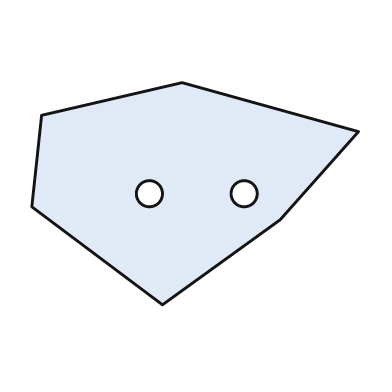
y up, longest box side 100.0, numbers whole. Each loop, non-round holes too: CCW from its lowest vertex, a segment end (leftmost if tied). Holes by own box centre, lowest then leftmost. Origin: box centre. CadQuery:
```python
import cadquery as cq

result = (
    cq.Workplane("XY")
    .moveTo(-10.0, -34.0)
    .lineTo(26.0, -8.0)
    .lineTo(50.0, 19.0)
    .lineTo(-4.0, 34.0)
    .lineTo(-47.0, 24.0)
    .lineTo(-50.0, -4.0)
    .close()
    .moveTo(-14.0, 0.0)
    .circle(4.0)
    .moveTo(15.0, 0.0)
    .circle(4.0)
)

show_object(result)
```